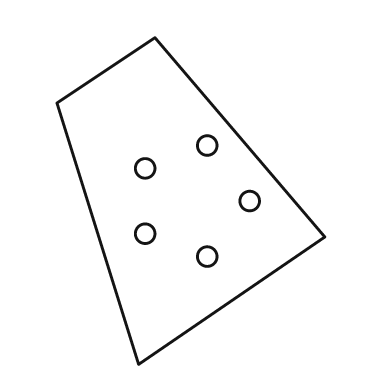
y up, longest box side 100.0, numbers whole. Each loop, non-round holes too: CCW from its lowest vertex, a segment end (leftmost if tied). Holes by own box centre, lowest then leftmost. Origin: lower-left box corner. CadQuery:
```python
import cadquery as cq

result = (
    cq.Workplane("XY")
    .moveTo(25.0, 0.0)
    .lineTo(82.0, 39.0)
    .lineTo(30.0, 100.0)
    .lineTo(0.0, 80.0)
    .close()
    .moveTo(46.0, 33.0)
    .circle(3.0)
    .moveTo(27.0, 40.0)
    .circle(3.0)
    .moveTo(59.0, 50.0)
    .circle(3.0)
    .moveTo(27.0, 60.0)
    .circle(3.0)
    .moveTo(46.0, 67.0)
    .circle(3.0)
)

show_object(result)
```